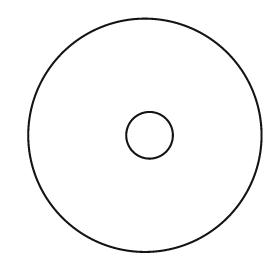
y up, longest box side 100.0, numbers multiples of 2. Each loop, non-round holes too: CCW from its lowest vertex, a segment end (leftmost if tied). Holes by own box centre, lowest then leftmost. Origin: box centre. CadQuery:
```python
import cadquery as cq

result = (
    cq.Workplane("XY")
    .moveTo(0.0, 0.0)
    .circle(50.0)
    .moveTo(2.0, 0.0)
    .circle(10.0)
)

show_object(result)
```